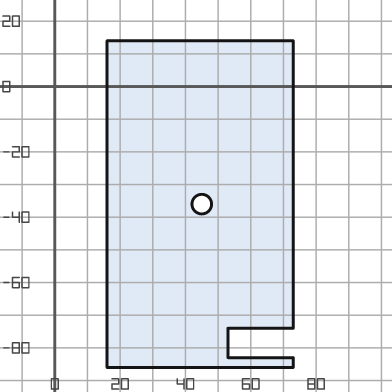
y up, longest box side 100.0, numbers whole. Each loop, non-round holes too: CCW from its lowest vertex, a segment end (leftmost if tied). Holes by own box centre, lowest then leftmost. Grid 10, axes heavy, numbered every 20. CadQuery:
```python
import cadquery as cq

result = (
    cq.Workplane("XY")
    .moveTo(16.0, -86.0)
    .lineTo(73.0, -86.0)
    .lineTo(73.0, -83.0)
    .lineTo(53.0, -83.0)
    .lineTo(53.0, -74.0)
    .lineTo(73.0, -74.0)
    .lineTo(73.0, 14.0)
    .lineTo(16.0, 14.0)
    .close()
    .moveTo(45.0, -36.0)
    .circle(3.0)
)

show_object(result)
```